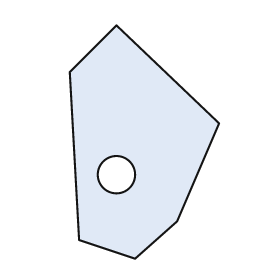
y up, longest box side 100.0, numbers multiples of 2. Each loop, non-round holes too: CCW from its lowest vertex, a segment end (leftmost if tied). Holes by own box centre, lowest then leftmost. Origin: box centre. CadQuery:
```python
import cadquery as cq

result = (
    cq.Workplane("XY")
    .moveTo(-4.0, -50.0)
    .lineTo(14.0, -34.0)
    .lineTo(32.0, 8.0)
    .lineTo(-12.0, 50.0)
    .lineTo(-32.0, 30.0)
    .lineTo(-28.0, -42.0)
    .close()
    .moveTo(-12.0, -14.0)
    .circle(8.0)
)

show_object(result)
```